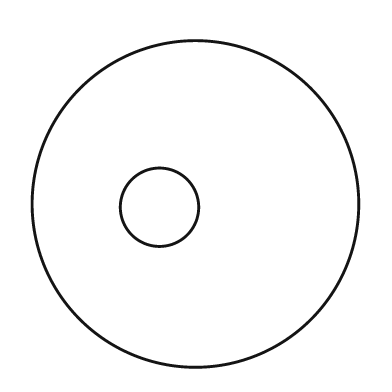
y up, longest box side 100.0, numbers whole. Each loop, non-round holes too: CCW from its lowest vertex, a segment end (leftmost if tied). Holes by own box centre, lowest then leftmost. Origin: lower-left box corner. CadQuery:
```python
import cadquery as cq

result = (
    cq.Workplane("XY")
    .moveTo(50.0, 50.0)
    .circle(50.0)
    .moveTo(39.0, 49.0)
    .circle(12.0)
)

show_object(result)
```